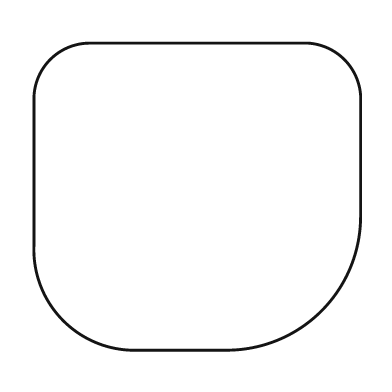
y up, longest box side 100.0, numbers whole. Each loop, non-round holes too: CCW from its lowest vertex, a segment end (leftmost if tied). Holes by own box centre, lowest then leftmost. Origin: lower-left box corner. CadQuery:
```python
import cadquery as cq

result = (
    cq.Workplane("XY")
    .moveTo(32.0, 0.0)
    .lineTo(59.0, 0.0)
    .threePointArc((88.0, 12.0), (100.0, 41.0))
    .lineTo(100.0, 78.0)
    .threePointArc((95.0, 89.0), (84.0, 94.0))
    .lineTo(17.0, 94.0)
    .threePointArc((5.0, 89.0), (0.0, 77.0))
    .lineTo(0.0, 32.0)
    .threePointArc((9.0, 9.0), (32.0, 0.0))
    .close()
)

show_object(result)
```